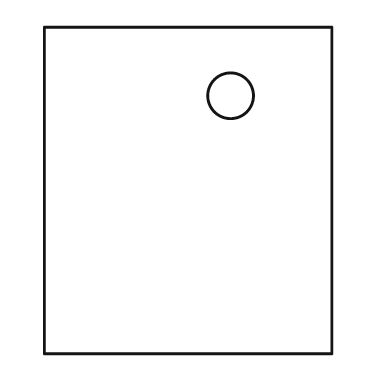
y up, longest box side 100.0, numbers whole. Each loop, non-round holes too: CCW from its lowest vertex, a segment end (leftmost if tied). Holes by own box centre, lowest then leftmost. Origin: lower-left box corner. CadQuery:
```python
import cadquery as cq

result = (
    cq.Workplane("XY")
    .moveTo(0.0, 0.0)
    .lineTo(88.0, 0.0)
    .lineTo(88.0, 100.0)
    .lineTo(0.0, 100.0)
    .close()
    .moveTo(57.0, 79.0)
    .circle(7.0)
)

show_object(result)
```